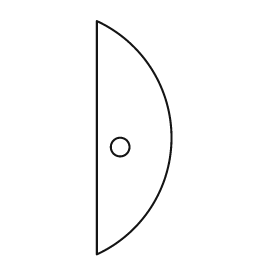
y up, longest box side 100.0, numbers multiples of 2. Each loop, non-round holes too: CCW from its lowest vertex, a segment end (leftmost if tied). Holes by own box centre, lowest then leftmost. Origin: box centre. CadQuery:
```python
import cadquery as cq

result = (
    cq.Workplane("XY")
    .moveTo(-16.0, -50.0)
    .threePointArc((16.0, 0.0), (-16.0, 50.0))
    .close()
    .moveTo(-6.0, -4.0)
    .circle(4.0)
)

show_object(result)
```